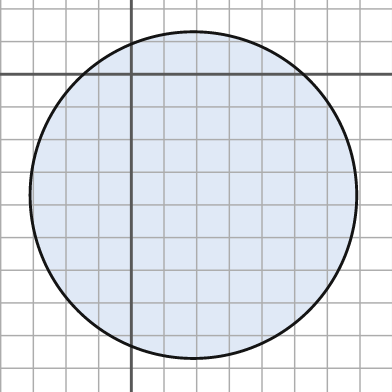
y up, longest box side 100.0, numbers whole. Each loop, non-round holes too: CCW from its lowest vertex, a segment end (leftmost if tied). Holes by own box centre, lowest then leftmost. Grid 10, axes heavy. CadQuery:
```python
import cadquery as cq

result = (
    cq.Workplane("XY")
    .moveTo(19.0, -37.0)
    .circle(50.0)
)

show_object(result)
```